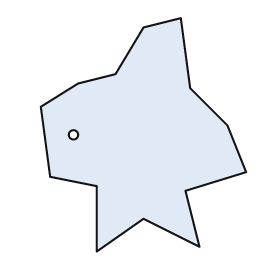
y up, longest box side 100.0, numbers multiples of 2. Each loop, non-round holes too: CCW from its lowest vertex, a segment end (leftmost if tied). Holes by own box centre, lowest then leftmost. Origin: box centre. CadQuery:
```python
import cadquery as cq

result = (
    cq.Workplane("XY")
    .moveTo(-20.0, -50.0)
    .lineTo(0.0, -36.0)
    .lineTo(24.0, -48.0)
    .lineTo(18.0, -24.0)
    .lineTo(44.0, -16.0)
    .lineTo(36.0, 4.0)
    .lineTo(20.0, 20.0)
    .lineTo(16.0, 50.0)
    .lineTo(0.0, 46.0)
    .lineTo(-12.0, 26.0)
    .lineTo(-28.0, 22.0)
    .lineTo(-44.0, 12.0)
    .lineTo(-40.0, -18.0)
    .lineTo(-20.0, -22.0)
    .close()
    .moveTo(-30.0, 0.0)
    .circle(2.0)
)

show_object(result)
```